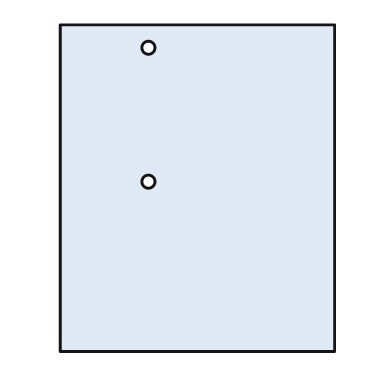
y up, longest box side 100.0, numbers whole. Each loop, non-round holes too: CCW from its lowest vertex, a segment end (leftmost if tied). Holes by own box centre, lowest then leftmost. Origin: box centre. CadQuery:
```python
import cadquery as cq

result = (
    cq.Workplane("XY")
    .moveTo(-42.0, -50.0)
    .lineTo(42.0, -50.0)
    .lineTo(42.0, 50.0)
    .lineTo(-42.0, 50.0)
    .close()
    .moveTo(-15.0, 2.0)
    .circle(2.0)
    .moveTo(-15.0, 43.0)
    .circle(2.0)
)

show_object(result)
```